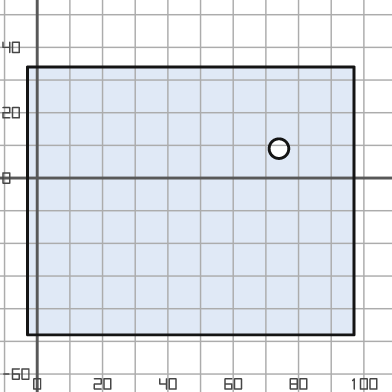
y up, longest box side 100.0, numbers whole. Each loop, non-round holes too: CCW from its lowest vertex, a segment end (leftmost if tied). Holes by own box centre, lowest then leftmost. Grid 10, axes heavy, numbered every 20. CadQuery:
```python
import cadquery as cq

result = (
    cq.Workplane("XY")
    .moveTo(-3.0, -48.0)
    .lineTo(97.0, -48.0)
    .lineTo(97.0, 34.0)
    .lineTo(-3.0, 34.0)
    .close()
    .moveTo(74.0, 9.0)
    .circle(3.0)
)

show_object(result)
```